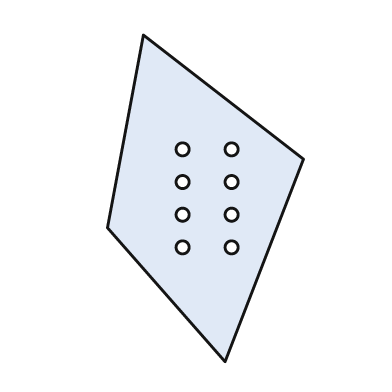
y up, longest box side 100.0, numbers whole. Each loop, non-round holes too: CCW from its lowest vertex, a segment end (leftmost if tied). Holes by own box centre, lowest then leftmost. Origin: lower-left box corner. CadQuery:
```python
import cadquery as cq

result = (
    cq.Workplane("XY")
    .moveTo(36.0, 0.0)
    .lineTo(60.0, 62.0)
    .lineTo(11.0, 100.0)
    .lineTo(0.0, 41.0)
    .close()
    .moveTo(23.0, 35.0)
    .circle(2.0)
    .moveTo(38.0, 35.0)
    .circle(2.0)
    .moveTo(23.0, 45.0)
    .circle(2.0)
    .moveTo(38.0, 45.0)
    .circle(2.0)
    .moveTo(23.0, 55.0)
    .circle(2.0)
    .moveTo(38.0, 55.0)
    .circle(2.0)
    .moveTo(23.0, 65.0)
    .circle(2.0)
    .moveTo(38.0, 65.0)
    .circle(2.0)
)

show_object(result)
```